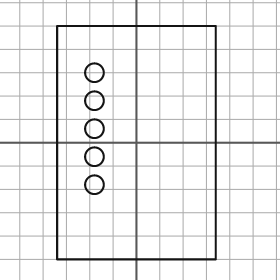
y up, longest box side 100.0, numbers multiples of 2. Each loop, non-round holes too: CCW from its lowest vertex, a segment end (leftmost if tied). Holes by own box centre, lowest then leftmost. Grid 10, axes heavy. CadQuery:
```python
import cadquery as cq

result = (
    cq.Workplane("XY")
    .moveTo(-34.0, -50.0)
    .lineTo(34.0, -50.0)
    .lineTo(34.0, 50.0)
    .lineTo(-34.0, 50.0)
    .close()
    .moveTo(-18.0, -18.0)
    .circle(4.0)
    .moveTo(-18.0, -6.0)
    .circle(4.0)
    .moveTo(-18.0, 6.0)
    .circle(4.0)
    .moveTo(-18.0, 18.0)
    .circle(4.0)
    .moveTo(-18.0, 30.0)
    .circle(4.0)
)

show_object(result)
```